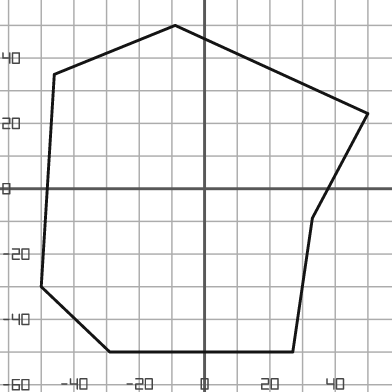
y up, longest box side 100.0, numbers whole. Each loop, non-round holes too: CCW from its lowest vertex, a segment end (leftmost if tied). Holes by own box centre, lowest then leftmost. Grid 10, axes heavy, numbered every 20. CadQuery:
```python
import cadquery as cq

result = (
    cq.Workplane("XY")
    .moveTo(-29.0, -50.0)
    .lineTo(27.0, -50.0)
    .lineTo(33.0, -9.0)
    .lineTo(50.0, 23.0)
    .lineTo(-9.0, 50.0)
    .lineTo(-46.0, 35.0)
    .lineTo(-50.0, -30.0)
    .close()
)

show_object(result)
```